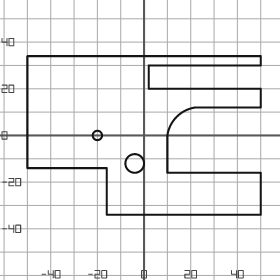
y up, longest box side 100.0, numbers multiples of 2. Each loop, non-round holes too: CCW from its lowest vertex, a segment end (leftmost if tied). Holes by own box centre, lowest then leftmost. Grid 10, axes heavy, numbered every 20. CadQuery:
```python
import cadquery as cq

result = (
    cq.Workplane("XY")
    .moveTo(-16.0, -34.0)
    .lineTo(50.0, -34.0)
    .lineTo(50.0, -16.0)
    .lineTo(10.0, -16.0)
    .lineTo(10.0, 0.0)
    .threePointArc((14.0, 8.0), (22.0, 12.0))
    .lineTo(50.0, 12.0)
    .lineTo(50.0, 20.0)
    .lineTo(2.0, 20.0)
    .lineTo(2.0, 30.0)
    .lineTo(50.0, 30.0)
    .lineTo(50.0, 34.0)
    .lineTo(-50.0, 34.0)
    .lineTo(-50.0, -14.0)
    .lineTo(-16.0, -14.0)
    .close()
    .moveTo(-4.0, -12.0)
    .circle(4.0)
    .moveTo(-20.0, 0.0)
    .circle(2.0)
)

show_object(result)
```